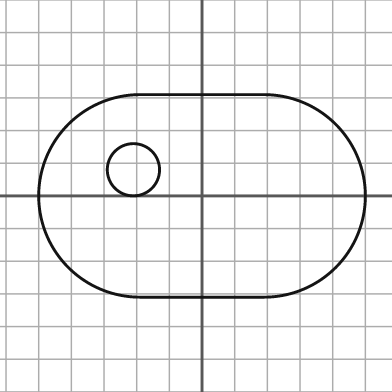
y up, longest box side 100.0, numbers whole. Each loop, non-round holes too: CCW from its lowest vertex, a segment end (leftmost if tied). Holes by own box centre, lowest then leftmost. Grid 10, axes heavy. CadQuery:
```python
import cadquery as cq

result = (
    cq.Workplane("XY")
    .moveTo(-19.0, -31.0)
    .lineTo(19.0, -31.0)
    .threePointArc((50.0, 0.0), (19.0, 31.0))
    .lineTo(-19.0, 31.0)
    .threePointArc((-50.0, 0.0), (-19.0, -31.0))
    .close()
    .moveTo(-21.0, 8.0)
    .circle(8.0)
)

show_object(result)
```